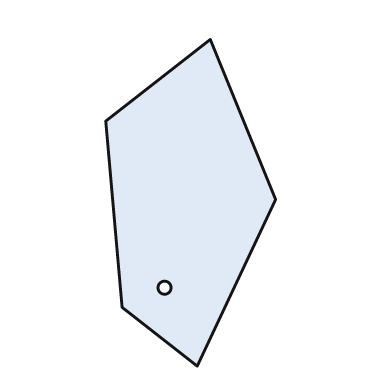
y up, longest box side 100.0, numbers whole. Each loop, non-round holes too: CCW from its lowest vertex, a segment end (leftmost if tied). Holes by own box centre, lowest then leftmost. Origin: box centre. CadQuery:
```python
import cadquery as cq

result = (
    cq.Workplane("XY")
    .moveTo(2.0, -50.0)
    .lineTo(26.0, 1.0)
    .lineTo(6.0, 50.0)
    .lineTo(-26.0, 25.0)
    .lineTo(-21.0, -32.0)
    .close()
    .moveTo(-8.0, -26.0)
    .circle(2.0)
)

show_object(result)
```